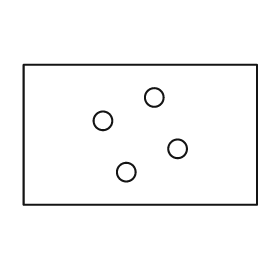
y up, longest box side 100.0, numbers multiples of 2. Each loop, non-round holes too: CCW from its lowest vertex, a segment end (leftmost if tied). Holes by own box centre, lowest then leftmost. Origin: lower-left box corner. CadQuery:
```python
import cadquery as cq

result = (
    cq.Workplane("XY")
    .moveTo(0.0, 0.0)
    .lineTo(100.0, 0.0)
    .lineTo(100.0, 60.0)
    .lineTo(0.0, 60.0)
    .close()
    .moveTo(44.0, 14.0)
    .circle(4.0)
    .moveTo(66.0, 24.0)
    .circle(4.0)
    .moveTo(34.0, 36.0)
    .circle(4.0)
    .moveTo(56.0, 46.0)
    .circle(4.0)
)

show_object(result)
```